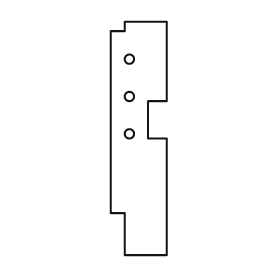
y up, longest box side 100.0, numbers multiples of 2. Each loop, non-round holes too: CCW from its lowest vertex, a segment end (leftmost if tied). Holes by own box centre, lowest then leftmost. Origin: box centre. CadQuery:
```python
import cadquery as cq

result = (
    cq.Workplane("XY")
    .moveTo(-6.0, -50.0)
    .lineTo(12.0, -50.0)
    .lineTo(12.0, 0.0)
    .lineTo(4.0, 0.0)
    .lineTo(4.0, 16.0)
    .lineTo(12.0, 16.0)
    .lineTo(12.0, 50.0)
    .lineTo(-6.0, 50.0)
    .lineTo(-6.0, 46.0)
    .lineTo(-12.0, 46.0)
    .lineTo(-12.0, -32.0)
    .lineTo(-6.0, -32.0)
    .close()
    .moveTo(-4.0, 2.0)
    .circle(2.0)
    .moveTo(-4.0, 18.0)
    .circle(2.0)
    .moveTo(-4.0, 34.0)
    .circle(2.0)
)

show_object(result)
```